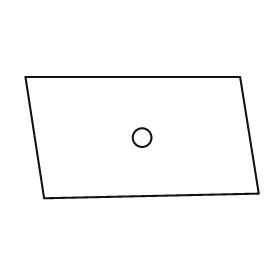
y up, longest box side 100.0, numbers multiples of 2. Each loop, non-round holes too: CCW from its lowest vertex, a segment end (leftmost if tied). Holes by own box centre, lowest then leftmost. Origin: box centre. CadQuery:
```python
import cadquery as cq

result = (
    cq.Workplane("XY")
    .moveTo(-42.0, -26.0)
    .lineTo(50.0, -24.0)
    .lineTo(42.0, 26.0)
    .lineTo(-50.0, 26.0)
    .close()
    .moveTo(0.0, 0.0)
    .circle(4.0)
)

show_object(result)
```